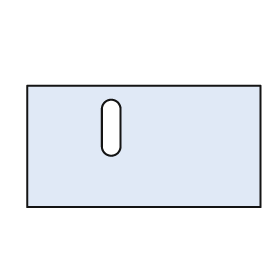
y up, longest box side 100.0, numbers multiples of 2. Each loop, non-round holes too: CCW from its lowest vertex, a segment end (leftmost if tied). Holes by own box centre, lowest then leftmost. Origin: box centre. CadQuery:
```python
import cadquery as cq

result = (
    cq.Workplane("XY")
    .moveTo(-50.0, -26.0)
    .lineTo(50.0, -26.0)
    .lineTo(50.0, 26.0)
    .lineTo(-50.0, 26.0)
    .close()
    .moveTo(-18.0, 0.0)
    .threePointArc((-14.0, -4.0), (-10.0, 0.0))
    .lineTo(-10.0, 16.0)
    .threePointArc((-14.0, 20.0), (-18.0, 16.0))
    .close()
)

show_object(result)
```